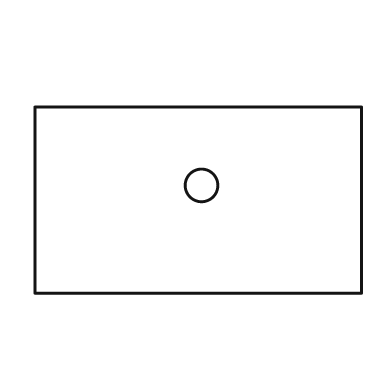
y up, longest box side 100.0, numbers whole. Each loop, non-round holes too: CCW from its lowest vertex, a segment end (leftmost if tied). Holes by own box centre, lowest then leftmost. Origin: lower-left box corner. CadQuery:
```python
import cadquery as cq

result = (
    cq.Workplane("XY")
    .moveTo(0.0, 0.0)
    .lineTo(100.0, 0.0)
    .lineTo(100.0, 57.0)
    .lineTo(0.0, 57.0)
    .close()
    .moveTo(51.0, 33.0)
    .circle(5.0)
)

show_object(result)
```